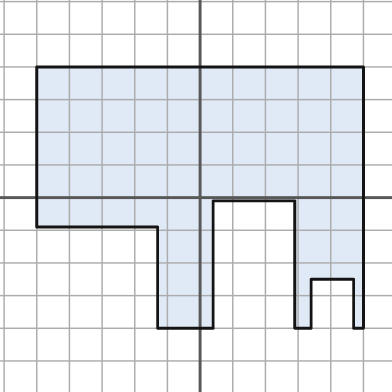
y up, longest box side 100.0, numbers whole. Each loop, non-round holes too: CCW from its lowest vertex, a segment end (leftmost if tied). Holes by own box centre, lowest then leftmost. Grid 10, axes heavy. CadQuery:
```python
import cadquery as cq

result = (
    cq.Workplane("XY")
    .moveTo(-13.0, -40.0)
    .lineTo(4.0, -40.0)
    .lineTo(4.0, -1.0)
    .lineTo(29.0, -1.0)
    .lineTo(29.0, -40.0)
    .lineTo(34.0, -40.0)
    .lineTo(34.0, -25.0)
    .lineTo(47.0, -25.0)
    .lineTo(47.0, -40.0)
    .lineTo(50.0, -40.0)
    .lineTo(50.0, 40.0)
    .lineTo(-50.0, 40.0)
    .lineTo(-50.0, -9.0)
    .lineTo(-13.0, -9.0)
    .close()
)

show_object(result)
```